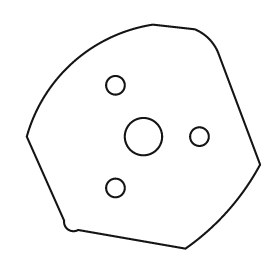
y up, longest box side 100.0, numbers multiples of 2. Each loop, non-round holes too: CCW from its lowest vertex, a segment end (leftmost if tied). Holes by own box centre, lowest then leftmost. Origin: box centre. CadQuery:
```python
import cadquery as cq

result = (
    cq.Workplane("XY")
    .moveTo(18.0, -48.0)
    .threePointArc((36.0, -32.0), (50.0, -12.0))
    .lineTo(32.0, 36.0)
    .threePointArc((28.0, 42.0), (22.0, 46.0))
    .lineTo(4.0, 48.0)
    .threePointArc((-30.0, 32.0), (-50.0, 0.0))
    .lineTo(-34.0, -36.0)
    .threePointArc((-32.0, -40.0), (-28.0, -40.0))
    .close()
    .moveTo(-12.0, -22.0)
    .circle(4.0)
    .moveTo(0.0, 0.0)
    .circle(8.0)
    .moveTo(24.0, 0.0)
    .circle(4.0)
    .moveTo(-12.0, 22.0)
    .circle(4.0)
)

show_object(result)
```